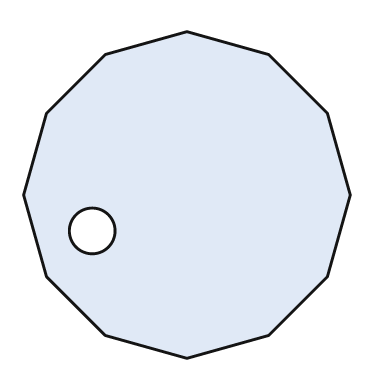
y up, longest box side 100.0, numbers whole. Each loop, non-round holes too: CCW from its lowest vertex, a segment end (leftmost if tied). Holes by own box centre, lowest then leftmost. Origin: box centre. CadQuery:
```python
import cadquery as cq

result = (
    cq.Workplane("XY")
    .moveTo(0.0, -50.0)
    .lineTo(25.0, -43.0)
    .lineTo(43.0, -25.0)
    .lineTo(50.0, 0.0)
    .lineTo(43.0, 25.0)
    .lineTo(25.0, 43.0)
    .lineTo(0.0, 50.0)
    .lineTo(-25.0, 43.0)
    .lineTo(-43.0, 25.0)
    .lineTo(-50.0, 0.0)
    .lineTo(-43.0, -25.0)
    .lineTo(-25.0, -43.0)
    .close()
    .moveTo(-29.0, -11.0)
    .circle(7.0)
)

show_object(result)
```